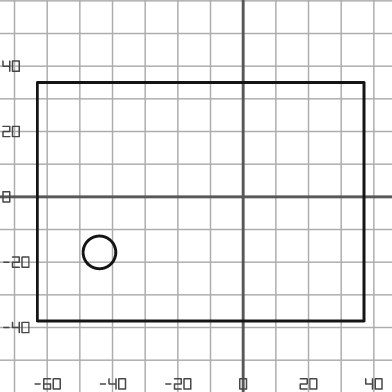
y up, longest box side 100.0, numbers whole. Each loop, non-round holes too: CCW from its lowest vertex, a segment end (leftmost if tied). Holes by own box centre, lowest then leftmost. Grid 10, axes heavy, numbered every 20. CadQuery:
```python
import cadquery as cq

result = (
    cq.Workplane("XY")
    .moveTo(-63.0, -38.0)
    .lineTo(37.0, -38.0)
    .lineTo(37.0, 35.0)
    .lineTo(-63.0, 35.0)
    .close()
    .moveTo(-44.0, -17.0)
    .circle(5.0)
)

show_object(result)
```